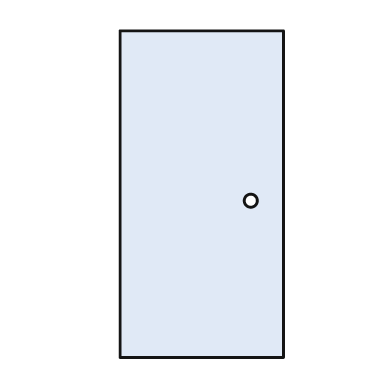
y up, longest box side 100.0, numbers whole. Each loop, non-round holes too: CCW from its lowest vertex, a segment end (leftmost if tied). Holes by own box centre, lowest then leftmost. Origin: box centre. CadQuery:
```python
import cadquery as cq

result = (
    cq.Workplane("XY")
    .moveTo(-25.0, -50.0)
    .lineTo(25.0, -50.0)
    .lineTo(25.0, 50.0)
    .lineTo(-25.0, 50.0)
    .close()
    .moveTo(15.0, -2.0)
    .circle(2.0)
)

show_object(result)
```